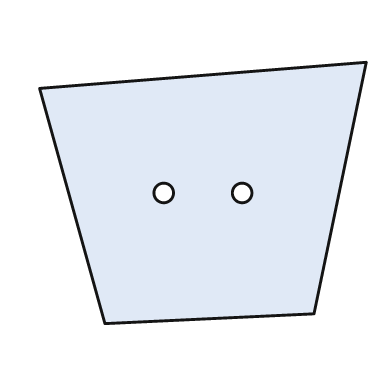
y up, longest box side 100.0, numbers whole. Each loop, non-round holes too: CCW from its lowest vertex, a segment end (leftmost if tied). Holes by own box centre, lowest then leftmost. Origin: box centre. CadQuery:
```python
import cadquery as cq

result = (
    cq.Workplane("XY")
    .moveTo(-30.0, -40.0)
    .lineTo(34.0, -37.0)
    .lineTo(50.0, 40.0)
    .lineTo(-50.0, 32.0)
    .close()
    .moveTo(-12.0, 0.0)
    .circle(3.0)
    .moveTo(12.0, 0.0)
    .circle(3.0)
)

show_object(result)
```